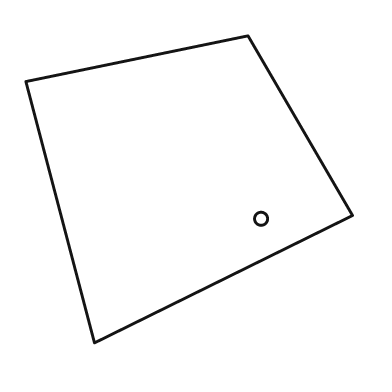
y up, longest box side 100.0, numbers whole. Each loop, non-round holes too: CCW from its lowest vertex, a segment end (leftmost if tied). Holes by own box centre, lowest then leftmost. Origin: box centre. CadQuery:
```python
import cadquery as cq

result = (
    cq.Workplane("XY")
    .moveTo(-29.0, -47.0)
    .lineTo(50.0, -8.0)
    .lineTo(18.0, 47.0)
    .lineTo(-50.0, 33.0)
    .close()
    .moveTo(22.0, -9.0)
    .circle(2.0)
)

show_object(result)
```